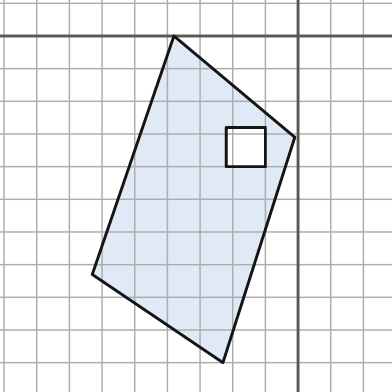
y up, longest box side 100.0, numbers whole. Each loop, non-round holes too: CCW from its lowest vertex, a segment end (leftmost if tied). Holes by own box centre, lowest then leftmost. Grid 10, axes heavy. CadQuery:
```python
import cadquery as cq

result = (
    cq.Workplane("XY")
    .moveTo(-23.0, -100.0)
    .lineTo(-1.0, -31.0)
    .lineTo(-38.0, 0.0)
    .lineTo(-63.0, -73.0)
    .close()
    .moveTo(-22.0, -40.0)
    .lineTo(-10.0, -40.0)
    .lineTo(-10.0, -28.0)
    .lineTo(-22.0, -28.0)
    .close()
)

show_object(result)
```